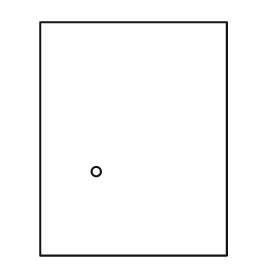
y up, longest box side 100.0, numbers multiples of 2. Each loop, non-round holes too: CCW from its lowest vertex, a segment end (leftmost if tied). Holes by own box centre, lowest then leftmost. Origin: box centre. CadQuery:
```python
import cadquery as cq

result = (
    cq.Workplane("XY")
    .moveTo(-40.0, -50.0)
    .lineTo(40.0, -50.0)
    .lineTo(40.0, 50.0)
    .lineTo(-40.0, 50.0)
    .close()
    .moveTo(-16.0, -14.0)
    .circle(2.0)
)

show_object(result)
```